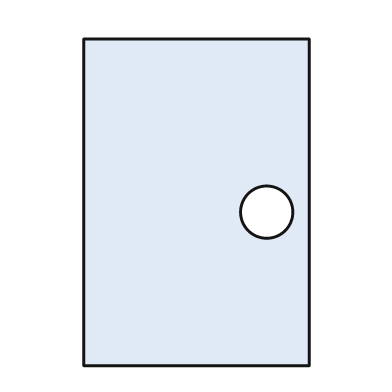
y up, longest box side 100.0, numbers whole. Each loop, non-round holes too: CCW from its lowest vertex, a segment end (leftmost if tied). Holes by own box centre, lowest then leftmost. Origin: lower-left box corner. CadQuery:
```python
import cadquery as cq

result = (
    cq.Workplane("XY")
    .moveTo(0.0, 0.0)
    .lineTo(69.0, 0.0)
    .lineTo(69.0, 100.0)
    .lineTo(0.0, 100.0)
    .close()
    .moveTo(56.0, 47.0)
    .circle(8.0)
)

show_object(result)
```